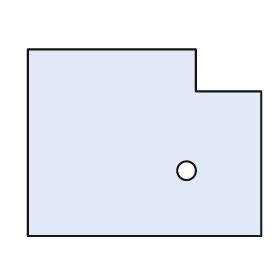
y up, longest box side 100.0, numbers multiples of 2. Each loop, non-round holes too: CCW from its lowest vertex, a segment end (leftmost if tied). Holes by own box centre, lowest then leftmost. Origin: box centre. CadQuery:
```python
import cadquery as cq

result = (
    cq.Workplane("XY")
    .moveTo(-50.0, -40.0)
    .lineTo(50.0, -40.0)
    .lineTo(50.0, 22.0)
    .lineTo(22.0, 22.0)
    .lineTo(22.0, 40.0)
    .lineTo(-50.0, 40.0)
    .close()
    .moveTo(18.0, -12.0)
    .circle(4.0)
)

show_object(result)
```